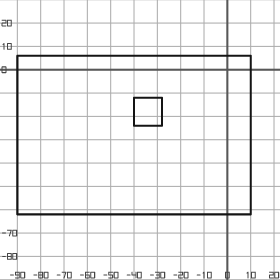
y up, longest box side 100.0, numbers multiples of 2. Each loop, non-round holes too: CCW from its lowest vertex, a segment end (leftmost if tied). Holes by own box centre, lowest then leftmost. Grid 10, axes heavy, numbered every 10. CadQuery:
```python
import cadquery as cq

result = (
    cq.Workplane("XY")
    .moveTo(-90.0, -62.0)
    .lineTo(10.0, -62.0)
    .lineTo(10.0, 6.0)
    .lineTo(-90.0, 6.0)
    .close()
    .moveTo(-40.0, -24.0)
    .lineTo(-28.0, -24.0)
    .lineTo(-28.0, -12.0)
    .lineTo(-40.0, -12.0)
    .close()
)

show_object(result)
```